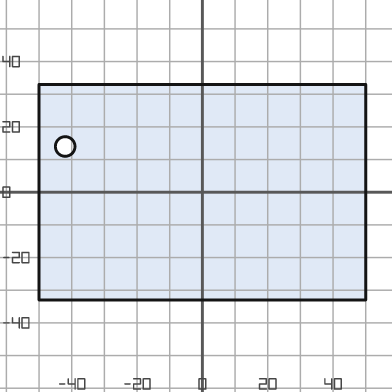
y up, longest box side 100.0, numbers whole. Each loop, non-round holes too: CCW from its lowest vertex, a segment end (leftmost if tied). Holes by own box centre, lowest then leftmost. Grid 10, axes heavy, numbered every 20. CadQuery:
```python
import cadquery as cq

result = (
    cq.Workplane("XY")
    .moveTo(-50.0, -33.0)
    .lineTo(50.0, -33.0)
    .lineTo(50.0, 33.0)
    .lineTo(-50.0, 33.0)
    .close()
    .moveTo(-42.0, 14.0)
    .circle(3.0)
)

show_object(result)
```